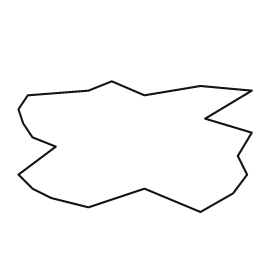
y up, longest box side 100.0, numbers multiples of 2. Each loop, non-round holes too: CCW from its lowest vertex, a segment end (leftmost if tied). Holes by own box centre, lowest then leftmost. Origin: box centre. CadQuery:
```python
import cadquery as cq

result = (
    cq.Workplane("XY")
    .moveTo(28.0, -28.0)
    .lineTo(42.0, -20.0)
    .lineTo(48.0, -12.0)
    .lineTo(44.0, -4.0)
    .lineTo(50.0, 6.0)
    .lineTo(30.0, 12.0)
    .lineTo(50.0, 24.0)
    .lineTo(28.0, 26.0)
    .lineTo(4.0, 22.0)
    .lineTo(-10.0, 28.0)
    .lineTo(-20.0, 24.0)
    .lineTo(-46.0, 22.0)
    .lineTo(-50.0, 16.0)
    .lineTo(-48.0, 10.0)
    .lineTo(-44.0, 4.0)
    .lineTo(-34.0, 0.0)
    .lineTo(-50.0, -12.0)
    .lineTo(-44.0, -18.0)
    .lineTo(-36.0, -22.0)
    .lineTo(-20.0, -26.0)
    .lineTo(4.0, -18.0)
    .close()
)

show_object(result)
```